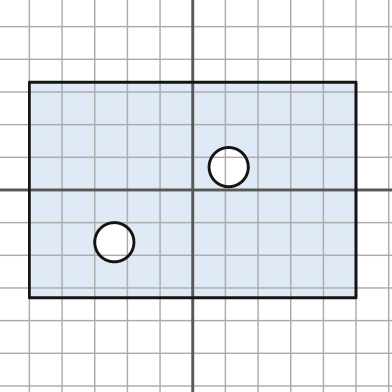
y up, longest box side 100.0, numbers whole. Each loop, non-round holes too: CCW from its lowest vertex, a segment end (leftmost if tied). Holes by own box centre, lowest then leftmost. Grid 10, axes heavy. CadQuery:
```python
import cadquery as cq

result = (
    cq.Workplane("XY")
    .moveTo(-50.0, -33.0)
    .lineTo(50.0, -33.0)
    .lineTo(50.0, 33.0)
    .lineTo(-50.0, 33.0)
    .close()
    .moveTo(-24.0, -16.0)
    .circle(6.0)
    .moveTo(11.0, 7.0)
    .circle(6.0)
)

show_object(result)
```